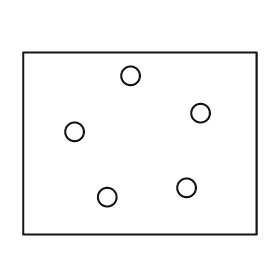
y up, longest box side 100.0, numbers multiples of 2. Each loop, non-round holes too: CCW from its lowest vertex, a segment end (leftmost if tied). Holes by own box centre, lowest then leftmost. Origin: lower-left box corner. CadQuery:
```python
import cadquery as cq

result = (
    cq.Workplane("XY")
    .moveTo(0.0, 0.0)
    .lineTo(100.0, 0.0)
    .lineTo(100.0, 78.0)
    .lineTo(0.0, 78.0)
    .close()
    .moveTo(36.0, 16.0)
    .circle(4.0)
    .moveTo(70.0, 20.0)
    .circle(4.0)
    .moveTo(22.0, 44.0)
    .circle(4.0)
    .moveTo(76.0, 52.0)
    .circle(4.0)
    .moveTo(46.0, 68.0)
    .circle(4.0)
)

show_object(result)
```